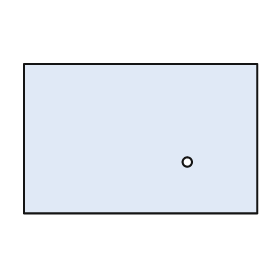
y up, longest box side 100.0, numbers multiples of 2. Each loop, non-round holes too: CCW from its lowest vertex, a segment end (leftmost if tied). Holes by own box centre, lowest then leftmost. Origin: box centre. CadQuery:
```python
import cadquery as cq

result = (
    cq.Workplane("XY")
    .moveTo(-50.0, -32.0)
    .lineTo(50.0, -32.0)
    .lineTo(50.0, 32.0)
    .lineTo(-50.0, 32.0)
    .close()
    .moveTo(20.0, -10.0)
    .circle(2.0)
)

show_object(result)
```